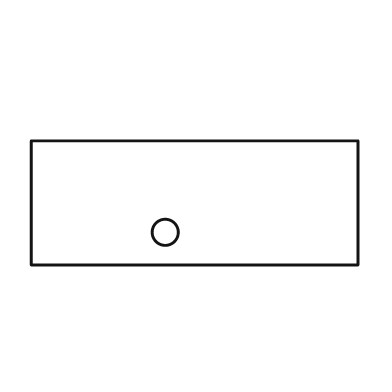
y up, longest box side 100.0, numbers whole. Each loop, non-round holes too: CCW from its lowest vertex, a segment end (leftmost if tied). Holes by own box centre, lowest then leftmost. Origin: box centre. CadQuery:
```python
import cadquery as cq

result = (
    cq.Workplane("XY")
    .moveTo(-50.0, -19.0)
    .lineTo(50.0, -19.0)
    .lineTo(50.0, 19.0)
    .lineTo(-50.0, 19.0)
    .close()
    .moveTo(-9.0, -9.0)
    .circle(4.0)
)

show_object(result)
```